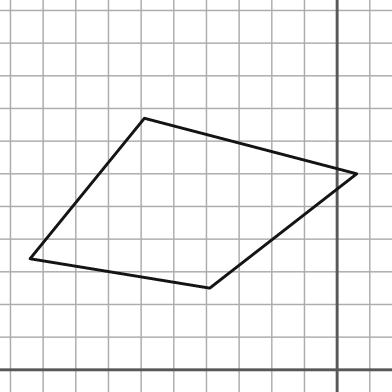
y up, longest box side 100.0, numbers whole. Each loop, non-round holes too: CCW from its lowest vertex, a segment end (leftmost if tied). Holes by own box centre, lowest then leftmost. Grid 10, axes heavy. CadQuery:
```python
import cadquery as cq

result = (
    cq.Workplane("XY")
    .moveTo(-39.0, 25.0)
    .lineTo(6.0, 60.0)
    .lineTo(-59.0, 77.0)
    .lineTo(-94.0, 34.0)
    .close()
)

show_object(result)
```